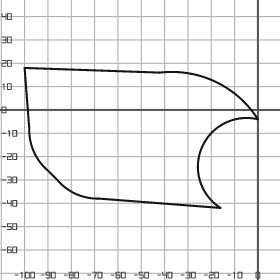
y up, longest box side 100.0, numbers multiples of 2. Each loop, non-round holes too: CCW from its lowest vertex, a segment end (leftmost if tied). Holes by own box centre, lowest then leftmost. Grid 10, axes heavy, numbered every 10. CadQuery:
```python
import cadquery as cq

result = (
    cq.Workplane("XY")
    .moveTo(-16.0, -42.0)
    .threePointArc((-24.0, -16.0), (0.0, -4.0))
    .threePointArc((-18.0, 12.0), (-42.0, 16.0))
    .lineTo(-100.0, 18.0)
    .lineTo(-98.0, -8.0)
    .threePointArc((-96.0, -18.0), (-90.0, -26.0))
    .lineTo(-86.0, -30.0)
    .threePointArc((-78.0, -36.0), (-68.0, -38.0))
    .close()
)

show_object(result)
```